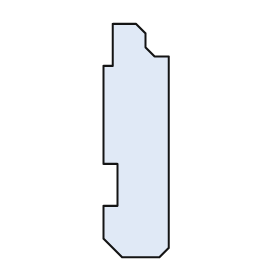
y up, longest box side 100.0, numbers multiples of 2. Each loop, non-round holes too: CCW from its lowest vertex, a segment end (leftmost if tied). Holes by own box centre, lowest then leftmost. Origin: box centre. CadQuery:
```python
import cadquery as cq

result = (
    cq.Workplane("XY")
    .moveTo(-6.0, -50.0)
    .lineTo(10.0, -50.0)
    .lineTo(14.0, -46.0)
    .lineTo(14.0, 36.0)
    .lineTo(8.0, 36.0)
    .lineTo(4.0, 40.0)
    .lineTo(4.0, 46.0)
    .lineTo(0.0, 50.0)
    .lineTo(-10.0, 50.0)
    .lineTo(-10.0, 32.0)
    .lineTo(-14.0, 32.0)
    .lineTo(-14.0, -10.0)
    .lineTo(-8.0, -10.0)
    .lineTo(-8.0, -28.0)
    .lineTo(-14.0, -28.0)
    .lineTo(-14.0, -42.0)
    .close()
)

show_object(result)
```